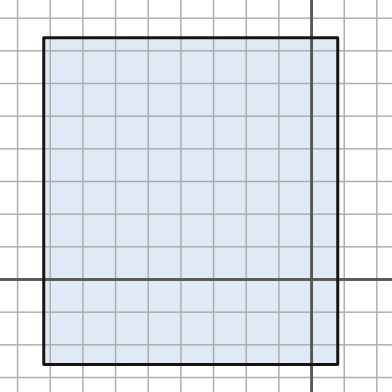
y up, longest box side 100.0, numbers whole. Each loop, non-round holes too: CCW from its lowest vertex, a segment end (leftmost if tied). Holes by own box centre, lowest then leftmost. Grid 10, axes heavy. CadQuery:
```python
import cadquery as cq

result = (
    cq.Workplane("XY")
    .moveTo(-82.0, -26.0)
    .lineTo(8.0, -26.0)
    .lineTo(8.0, 74.0)
    .lineTo(-82.0, 74.0)
    .close()
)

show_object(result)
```